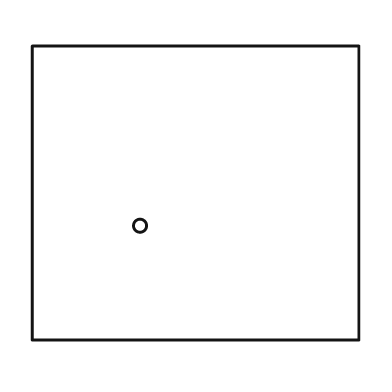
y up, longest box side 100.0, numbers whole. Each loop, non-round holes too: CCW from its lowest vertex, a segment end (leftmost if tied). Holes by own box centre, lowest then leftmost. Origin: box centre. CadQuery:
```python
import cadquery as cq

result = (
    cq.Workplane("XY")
    .moveTo(-50.0, -45.0)
    .lineTo(50.0, -45.0)
    .lineTo(50.0, 45.0)
    .lineTo(-50.0, 45.0)
    .close()
    .moveTo(-17.0, -10.0)
    .circle(2.0)
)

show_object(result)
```